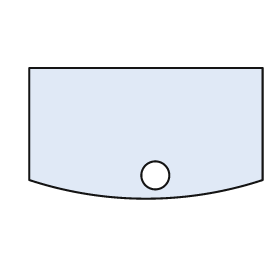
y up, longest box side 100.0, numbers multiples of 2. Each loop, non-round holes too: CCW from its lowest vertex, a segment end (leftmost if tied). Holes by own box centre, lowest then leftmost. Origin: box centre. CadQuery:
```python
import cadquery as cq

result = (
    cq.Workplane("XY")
    .moveTo(-50.0, -20.0)
    .threePointArc((0.0, -28.0), (50.0, -20.0))
    .lineTo(50.0, 28.0)
    .lineTo(-50.0, 28.0)
    .close()
    .moveTo(4.0, -18.0)
    .circle(6.0)
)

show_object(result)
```